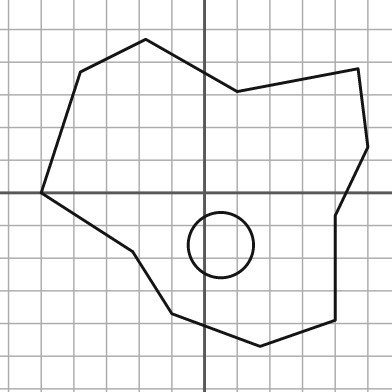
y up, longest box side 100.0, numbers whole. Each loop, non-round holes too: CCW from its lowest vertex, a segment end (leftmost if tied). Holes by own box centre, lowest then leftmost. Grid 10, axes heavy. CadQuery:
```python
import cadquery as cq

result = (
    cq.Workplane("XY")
    .moveTo(17.0, -47.0)
    .lineTo(40.0, -39.0)
    .lineTo(40.0, -7.0)
    .lineTo(50.0, 14.0)
    .lineTo(47.0, 38.0)
    .lineTo(10.0, 31.0)
    .lineTo(-18.0, 47.0)
    .lineTo(-38.0, 37.0)
    .lineTo(-50.0, 0.0)
    .lineTo(-22.0, -18.0)
    .lineTo(-10.0, -37.0)
    .close()
    .moveTo(5.0, -16.0)
    .circle(10.0)
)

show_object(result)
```